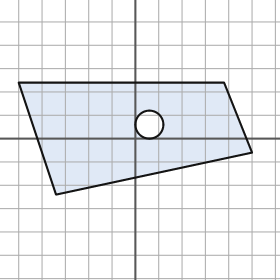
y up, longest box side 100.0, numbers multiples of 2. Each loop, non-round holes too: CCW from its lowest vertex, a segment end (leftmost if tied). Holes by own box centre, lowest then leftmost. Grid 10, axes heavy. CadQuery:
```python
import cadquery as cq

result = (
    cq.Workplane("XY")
    .moveTo(-34.0, -24.0)
    .lineTo(50.0, -6.0)
    .lineTo(38.0, 24.0)
    .lineTo(-50.0, 24.0)
    .close()
    .moveTo(6.0, 6.0)
    .circle(6.0)
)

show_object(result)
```